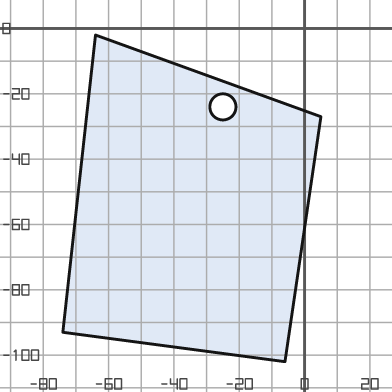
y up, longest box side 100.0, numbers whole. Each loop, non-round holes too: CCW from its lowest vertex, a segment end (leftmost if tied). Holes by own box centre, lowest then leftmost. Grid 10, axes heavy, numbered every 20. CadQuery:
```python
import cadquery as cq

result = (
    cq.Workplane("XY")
    .moveTo(-6.0, -102.0)
    .lineTo(5.0, -27.0)
    .lineTo(-64.0, -2.0)
    .lineTo(-74.0, -93.0)
    .close()
    .moveTo(-25.0, -24.0)
    .circle(4.0)
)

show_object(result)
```